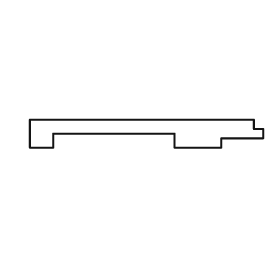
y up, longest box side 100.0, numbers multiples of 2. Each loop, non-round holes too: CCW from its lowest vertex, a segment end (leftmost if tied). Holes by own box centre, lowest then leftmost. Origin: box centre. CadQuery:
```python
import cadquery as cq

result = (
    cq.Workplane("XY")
    .moveTo(-50.0, -6.0)
    .lineTo(-40.0, -6.0)
    .lineTo(-40.0, 0.0)
    .lineTo(12.0, 0.0)
    .lineTo(12.0, -6.0)
    .lineTo(32.0, -6.0)
    .lineTo(32.0, -2.0)
    .lineTo(50.0, -2.0)
    .lineTo(50.0, 2.0)
    .lineTo(46.0, 2.0)
    .lineTo(46.0, 6.0)
    .lineTo(-50.0, 6.0)
    .close()
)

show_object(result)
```